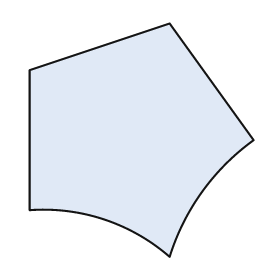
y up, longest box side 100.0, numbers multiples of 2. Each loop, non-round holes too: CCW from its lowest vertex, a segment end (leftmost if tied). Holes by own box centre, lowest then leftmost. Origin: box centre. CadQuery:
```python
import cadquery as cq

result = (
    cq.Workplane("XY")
    .moveTo(12.0, -50.0)
    .threePointArc((26.0, -22.0), (48.0, 0.0))
    .lineTo(12.0, 50.0)
    .lineTo(-48.0, 30.0)
    .lineTo(-48.0, -30.0)
    .threePointArc((-16.0, -34.0), (12.0, -50.0))
    .close()
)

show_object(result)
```